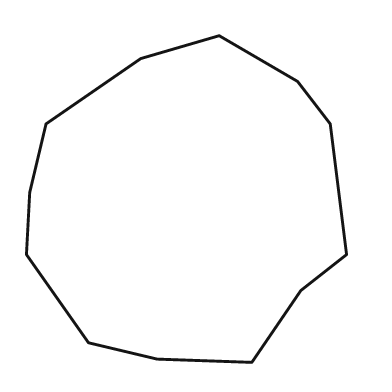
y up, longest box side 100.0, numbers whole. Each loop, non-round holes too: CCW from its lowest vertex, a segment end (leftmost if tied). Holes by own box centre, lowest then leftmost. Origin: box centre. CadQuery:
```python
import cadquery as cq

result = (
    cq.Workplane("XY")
    .moveTo(20.0, -50.0)
    .lineTo(35.0, -28.0)
    .lineTo(49.0, -17.0)
    .lineTo(44.0, 23.0)
    .lineTo(34.0, 36.0)
    .lineTo(10.0, 50.0)
    .lineTo(-14.0, 43.0)
    .lineTo(-43.0, 23.0)
    .lineTo(-48.0, 2.0)
    .lineTo(-49.0, -17.0)
    .lineTo(-30.0, -44.0)
    .lineTo(-9.0, -49.0)
    .close()
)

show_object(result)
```